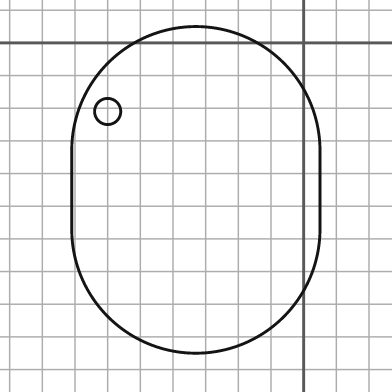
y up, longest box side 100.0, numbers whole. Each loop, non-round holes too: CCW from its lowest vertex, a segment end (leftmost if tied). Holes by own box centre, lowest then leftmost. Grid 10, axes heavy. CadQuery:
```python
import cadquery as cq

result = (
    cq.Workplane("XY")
    .moveTo(-71.0, -57.0)
    .threePointArc((-33.0, -95.0), (5.0, -57.0))
    .lineTo(5.0, -33.0)
    .threePointArc((-33.0, 5.0), (-71.0, -33.0))
    .close()
    .moveTo(-60.0, -21.0)
    .circle(4.0)
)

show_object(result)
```